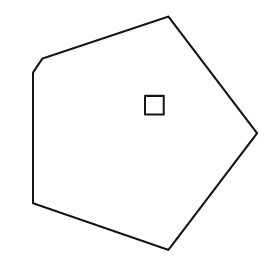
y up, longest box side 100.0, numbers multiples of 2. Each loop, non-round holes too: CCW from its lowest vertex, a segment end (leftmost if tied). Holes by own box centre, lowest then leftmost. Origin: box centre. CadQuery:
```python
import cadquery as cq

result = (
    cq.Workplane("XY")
    .moveTo(10.0, -50.0)
    .lineTo(48.0, 0.0)
    .lineTo(10.0, 50.0)
    .lineTo(-44.0, 32.0)
    .lineTo(-48.0, 26.0)
    .lineTo(-48.0, -30.0)
    .close()
    .moveTo(0.0, 8.0)
    .lineTo(8.0, 8.0)
    .lineTo(8.0, 16.0)
    .lineTo(0.0, 16.0)
    .close()
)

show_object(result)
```